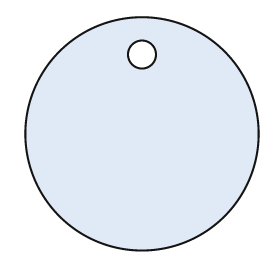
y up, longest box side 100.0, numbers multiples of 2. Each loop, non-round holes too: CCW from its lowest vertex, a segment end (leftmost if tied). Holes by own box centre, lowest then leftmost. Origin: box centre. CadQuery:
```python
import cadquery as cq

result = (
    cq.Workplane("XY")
    .moveTo(0.0, 0.0)
    .circle(50.0)
    .moveTo(0.0, 34.0)
    .circle(6.0)
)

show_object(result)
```